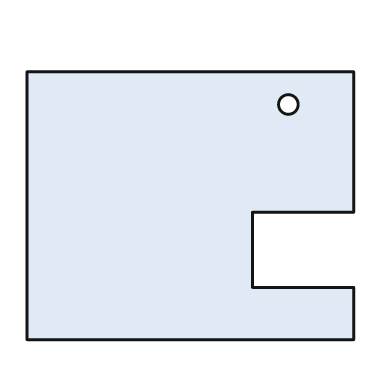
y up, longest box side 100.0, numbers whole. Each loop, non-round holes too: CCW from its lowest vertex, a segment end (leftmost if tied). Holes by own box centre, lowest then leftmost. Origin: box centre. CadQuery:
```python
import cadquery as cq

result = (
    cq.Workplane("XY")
    .moveTo(-50.0, -41.0)
    .lineTo(50.0, -41.0)
    .lineTo(50.0, -25.0)
    .lineTo(19.0, -25.0)
    .lineTo(19.0, -2.0)
    .lineTo(50.0, -2.0)
    .lineTo(50.0, 41.0)
    .lineTo(-50.0, 41.0)
    .close()
    .moveTo(30.0, 31.0)
    .circle(3.0)
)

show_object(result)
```